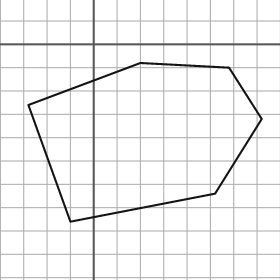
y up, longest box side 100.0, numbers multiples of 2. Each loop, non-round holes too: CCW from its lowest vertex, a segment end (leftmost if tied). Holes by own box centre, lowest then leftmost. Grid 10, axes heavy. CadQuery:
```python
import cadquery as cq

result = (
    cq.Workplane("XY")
    .moveTo(-10.0, -76.0)
    .lineTo(52.0, -64.0)
    .lineTo(72.0, -32.0)
    .lineTo(58.0, -10.0)
    .lineTo(20.0, -8.0)
    .lineTo(-28.0, -26.0)
    .close()
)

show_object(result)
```